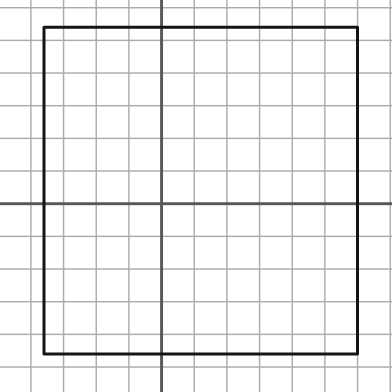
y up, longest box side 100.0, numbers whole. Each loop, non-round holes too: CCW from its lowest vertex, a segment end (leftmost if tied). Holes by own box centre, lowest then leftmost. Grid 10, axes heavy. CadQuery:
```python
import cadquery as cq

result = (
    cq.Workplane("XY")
    .moveTo(-36.0, -46.0)
    .lineTo(60.0, -46.0)
    .lineTo(60.0, 54.0)
    .lineTo(-36.0, 54.0)
    .close()
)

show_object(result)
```